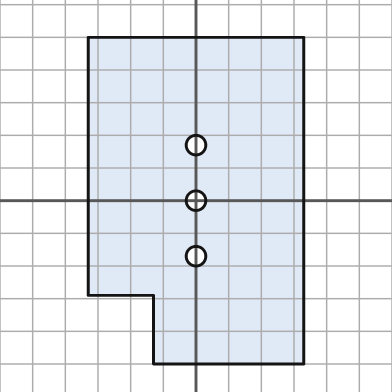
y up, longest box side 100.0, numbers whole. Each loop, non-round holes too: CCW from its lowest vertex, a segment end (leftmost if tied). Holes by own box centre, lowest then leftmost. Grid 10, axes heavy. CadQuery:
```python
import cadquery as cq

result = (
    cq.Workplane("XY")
    .moveTo(-13.0, -50.0)
    .lineTo(33.0, -50.0)
    .lineTo(33.0, 50.0)
    .lineTo(-33.0, 50.0)
    .lineTo(-33.0, -29.0)
    .lineTo(-13.0, -29.0)
    .close()
    .moveTo(0.0, -17.0)
    .circle(3.0)
    .moveTo(0.0, 0.0)
    .circle(3.0)
    .moveTo(0.0, 17.0)
    .circle(3.0)
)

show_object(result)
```